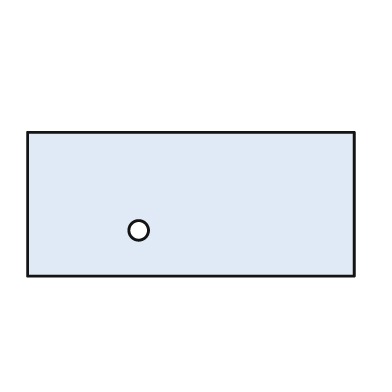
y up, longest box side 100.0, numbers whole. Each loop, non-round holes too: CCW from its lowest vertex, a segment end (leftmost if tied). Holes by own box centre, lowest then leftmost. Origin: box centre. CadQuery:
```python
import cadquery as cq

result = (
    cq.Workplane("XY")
    .moveTo(-50.0, -22.0)
    .lineTo(50.0, -22.0)
    .lineTo(50.0, 22.0)
    .lineTo(-50.0, 22.0)
    .close()
    .moveTo(-16.0, -8.0)
    .circle(3.0)
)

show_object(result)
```